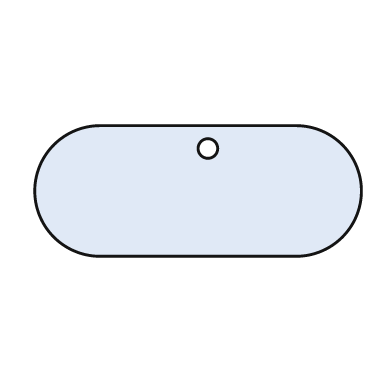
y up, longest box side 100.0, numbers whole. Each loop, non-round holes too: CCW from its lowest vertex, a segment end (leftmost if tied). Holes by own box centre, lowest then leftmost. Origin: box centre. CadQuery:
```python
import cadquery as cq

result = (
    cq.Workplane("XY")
    .moveTo(-30.0, -20.0)
    .lineTo(30.0, -20.0)
    .threePointArc((50.0, 0.0), (30.0, 20.0))
    .lineTo(-30.0, 20.0)
    .threePointArc((-50.0, 0.0), (-30.0, -20.0))
    .close()
    .moveTo(3.0, 13.0)
    .circle(3.0)
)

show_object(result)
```